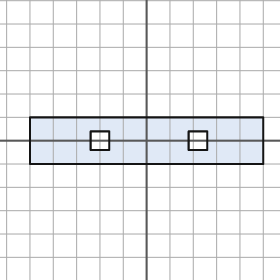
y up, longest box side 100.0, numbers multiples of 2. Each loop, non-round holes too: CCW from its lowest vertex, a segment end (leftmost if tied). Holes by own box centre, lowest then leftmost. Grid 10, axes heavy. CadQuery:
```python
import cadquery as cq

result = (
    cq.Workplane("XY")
    .moveTo(-50.0, -10.0)
    .lineTo(50.0, -10.0)
    .lineTo(50.0, 10.0)
    .lineTo(-50.0, 10.0)
    .close()
    .moveTo(-24.0, -4.0)
    .lineTo(-16.0, -4.0)
    .lineTo(-16.0, 4.0)
    .lineTo(-24.0, 4.0)
    .close()
    .moveTo(18.0, -4.0)
    .lineTo(26.0, -4.0)
    .lineTo(26.0, 4.0)
    .lineTo(18.0, 4.0)
    .close()
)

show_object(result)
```